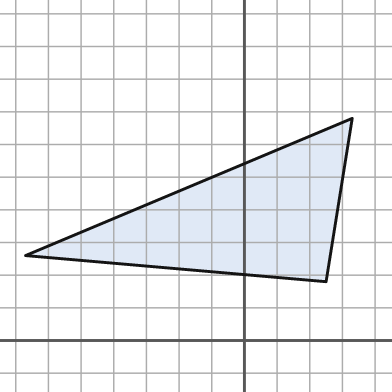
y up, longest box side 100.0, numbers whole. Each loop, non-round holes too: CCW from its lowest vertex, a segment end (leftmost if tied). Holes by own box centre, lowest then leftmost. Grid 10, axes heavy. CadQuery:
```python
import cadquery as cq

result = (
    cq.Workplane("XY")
    .moveTo(25.0, 18.0)
    .lineTo(33.0, 68.0)
    .lineTo(-67.0, 26.0)
    .close()
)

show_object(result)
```